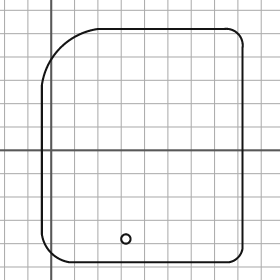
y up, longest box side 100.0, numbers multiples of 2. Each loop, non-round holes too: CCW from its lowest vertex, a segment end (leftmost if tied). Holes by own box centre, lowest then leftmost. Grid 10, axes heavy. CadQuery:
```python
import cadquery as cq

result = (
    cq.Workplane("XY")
    .moveTo(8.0, -48.0)
    .lineTo(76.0, -48.0)
    .threePointArc((80.0, -46.0), (82.0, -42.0))
    .lineTo(82.0, 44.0)
    .threePointArc((80.0, 50.0), (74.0, 52.0))
    .lineTo(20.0, 52.0)
    .threePointArc((4.0, 44.0), (-4.0, 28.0))
    .lineTo(-4.0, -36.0)
    .threePointArc((0.0, -44.0), (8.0, -48.0))
    .close()
    .moveTo(32.0, -38.0)
    .circle(2.0)
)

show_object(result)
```